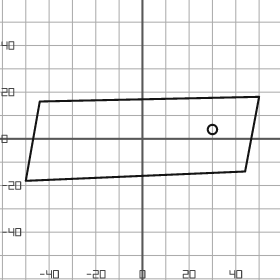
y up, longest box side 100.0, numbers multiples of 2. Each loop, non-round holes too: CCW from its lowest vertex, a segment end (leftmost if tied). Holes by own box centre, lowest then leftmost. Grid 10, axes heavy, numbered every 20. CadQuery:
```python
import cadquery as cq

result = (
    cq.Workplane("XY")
    .moveTo(-50.0, -18.0)
    .lineTo(44.0, -14.0)
    .lineTo(50.0, 18.0)
    .lineTo(-44.0, 16.0)
    .close()
    .moveTo(30.0, 4.0)
    .circle(2.0)
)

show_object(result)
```